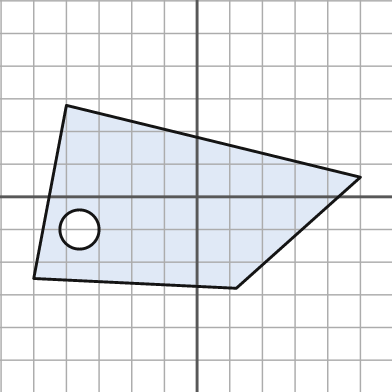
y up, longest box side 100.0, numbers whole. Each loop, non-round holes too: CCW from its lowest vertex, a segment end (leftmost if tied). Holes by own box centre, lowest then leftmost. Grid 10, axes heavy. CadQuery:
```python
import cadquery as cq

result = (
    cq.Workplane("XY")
    .moveTo(12.0, -28.0)
    .lineTo(50.0, 6.0)
    .lineTo(-40.0, 28.0)
    .lineTo(-50.0, -25.0)
    .close()
    .moveTo(-36.0, -10.0)
    .circle(6.0)
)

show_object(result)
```